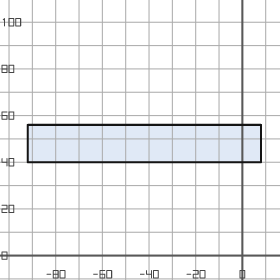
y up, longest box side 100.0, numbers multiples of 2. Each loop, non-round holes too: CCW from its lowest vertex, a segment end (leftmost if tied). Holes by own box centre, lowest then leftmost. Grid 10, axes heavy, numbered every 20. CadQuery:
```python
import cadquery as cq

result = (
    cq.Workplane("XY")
    .moveTo(-92.0, 40.0)
    .lineTo(8.0, 40.0)
    .lineTo(8.0, 56.0)
    .lineTo(-92.0, 56.0)
    .close()
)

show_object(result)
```